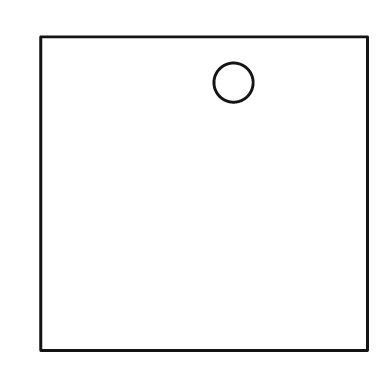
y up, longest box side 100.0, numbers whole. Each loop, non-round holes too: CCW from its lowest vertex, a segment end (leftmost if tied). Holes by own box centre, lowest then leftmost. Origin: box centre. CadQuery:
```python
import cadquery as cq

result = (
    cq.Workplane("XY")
    .moveTo(-50.0, -48.0)
    .lineTo(50.0, -48.0)
    .lineTo(50.0, 48.0)
    .lineTo(-50.0, 48.0)
    .close()
    .moveTo(9.0, 34.0)
    .circle(6.0)
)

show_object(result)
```